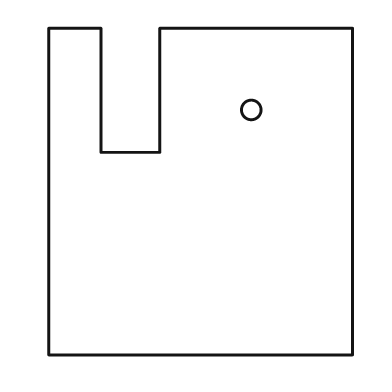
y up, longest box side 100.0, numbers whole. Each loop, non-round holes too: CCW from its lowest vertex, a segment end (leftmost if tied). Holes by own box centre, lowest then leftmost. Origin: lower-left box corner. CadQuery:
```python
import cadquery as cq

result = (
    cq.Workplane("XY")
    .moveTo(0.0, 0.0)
    .lineTo(93.0, 0.0)
    .lineTo(93.0, 100.0)
    .lineTo(34.0, 100.0)
    .lineTo(34.0, 62.0)
    .lineTo(16.0, 62.0)
    .lineTo(16.0, 100.0)
    .lineTo(0.0, 100.0)
    .close()
    .moveTo(62.0, 75.0)
    .circle(3.0)
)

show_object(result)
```